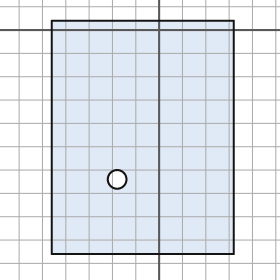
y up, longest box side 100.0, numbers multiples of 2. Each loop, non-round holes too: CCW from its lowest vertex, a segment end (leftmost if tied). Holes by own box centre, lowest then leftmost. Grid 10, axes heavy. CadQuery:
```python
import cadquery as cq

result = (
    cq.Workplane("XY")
    .moveTo(-46.0, -96.0)
    .lineTo(32.0, -96.0)
    .lineTo(32.0, 4.0)
    .lineTo(-46.0, 4.0)
    .close()
    .moveTo(-18.0, -64.0)
    .circle(4.0)
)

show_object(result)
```